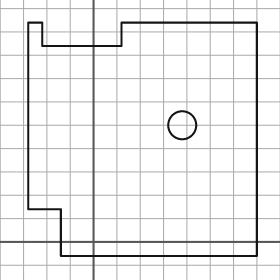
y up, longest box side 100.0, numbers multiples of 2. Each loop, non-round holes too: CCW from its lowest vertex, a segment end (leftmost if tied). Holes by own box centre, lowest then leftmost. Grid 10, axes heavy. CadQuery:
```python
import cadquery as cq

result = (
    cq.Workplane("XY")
    .moveTo(-14.0, -6.0)
    .lineTo(70.0, -6.0)
    .lineTo(70.0, 94.0)
    .lineTo(12.0, 94.0)
    .lineTo(12.0, 84.0)
    .lineTo(-22.0, 84.0)
    .lineTo(-22.0, 94.0)
    .lineTo(-28.0, 94.0)
    .lineTo(-28.0, 14.0)
    .lineTo(-14.0, 14.0)
    .close()
    .moveTo(38.0, 50.0)
    .circle(6.0)
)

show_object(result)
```